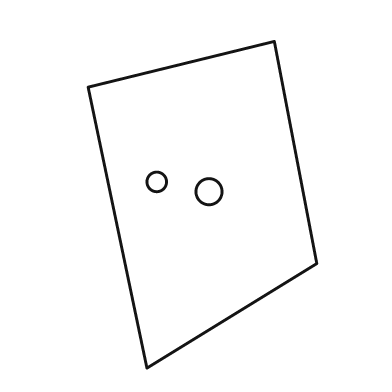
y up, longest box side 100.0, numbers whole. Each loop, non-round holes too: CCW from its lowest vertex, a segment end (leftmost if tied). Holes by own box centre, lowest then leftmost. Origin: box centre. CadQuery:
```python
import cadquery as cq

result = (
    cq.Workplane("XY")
    .moveTo(-17.0, -50.0)
    .lineTo(35.0, -18.0)
    .lineTo(22.0, 50.0)
    .lineTo(-35.0, 36.0)
    .close()
    .moveTo(2.0, 4.0)
    .circle(4.0)
    .moveTo(-14.0, 7.0)
    .circle(3.0)
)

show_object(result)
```